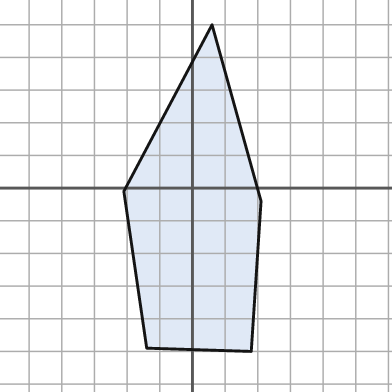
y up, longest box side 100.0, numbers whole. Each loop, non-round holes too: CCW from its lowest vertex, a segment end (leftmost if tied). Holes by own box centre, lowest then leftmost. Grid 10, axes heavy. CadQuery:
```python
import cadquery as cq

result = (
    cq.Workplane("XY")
    .moveTo(18.0, -50.0)
    .lineTo(21.0, -4.0)
    .lineTo(6.0, 50.0)
    .lineTo(-21.0, -1.0)
    .lineTo(-14.0, -49.0)
    .close()
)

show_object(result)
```